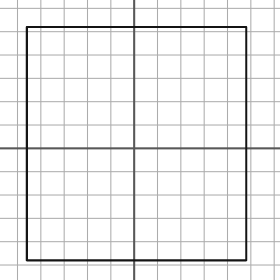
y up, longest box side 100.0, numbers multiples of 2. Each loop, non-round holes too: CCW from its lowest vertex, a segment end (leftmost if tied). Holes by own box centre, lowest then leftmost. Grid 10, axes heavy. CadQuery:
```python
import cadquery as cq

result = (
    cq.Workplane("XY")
    .moveTo(-46.0, -48.0)
    .lineTo(48.0, -48.0)
    .lineTo(48.0, 52.0)
    .lineTo(-46.0, 52.0)
    .close()
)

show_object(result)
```